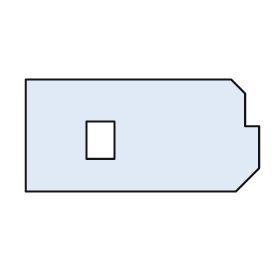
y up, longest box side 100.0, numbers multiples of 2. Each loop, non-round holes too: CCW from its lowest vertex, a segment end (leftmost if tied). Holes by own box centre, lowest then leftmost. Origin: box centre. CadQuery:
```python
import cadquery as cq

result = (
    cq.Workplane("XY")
    .moveTo(-50.0, -24.0)
    .lineTo(40.0, -24.0)
    .lineTo(50.0, -14.0)
    .lineTo(50.0, 4.0)
    .lineTo(44.0, 4.0)
    .lineTo(44.0, 18.0)
    .lineTo(38.0, 24.0)
    .lineTo(-50.0, 24.0)
    .close()
    .moveTo(-24.0, -10.0)
    .lineTo(-12.0, -10.0)
    .lineTo(-12.0, 6.0)
    .lineTo(-24.0, 6.0)
    .close()
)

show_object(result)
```